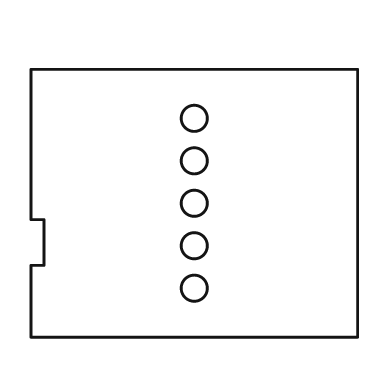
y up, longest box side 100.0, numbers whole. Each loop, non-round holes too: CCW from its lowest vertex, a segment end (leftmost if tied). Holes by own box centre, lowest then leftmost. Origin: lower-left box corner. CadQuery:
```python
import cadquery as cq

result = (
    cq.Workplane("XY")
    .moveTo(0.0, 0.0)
    .lineTo(100.0, 0.0)
    .lineTo(100.0, 82.0)
    .lineTo(0.0, 82.0)
    .lineTo(0.0, 36.0)
    .lineTo(4.0, 36.0)
    .lineTo(4.0, 22.0)
    .lineTo(0.0, 22.0)
    .close()
    .moveTo(50.0, 15.0)
    .circle(4.0)
    .moveTo(50.0, 28.0)
    .circle(4.0)
    .moveTo(50.0, 41.0)
    .circle(4.0)
    .moveTo(50.0, 54.0)
    .circle(4.0)
    .moveTo(50.0, 67.0)
    .circle(4.0)
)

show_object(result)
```